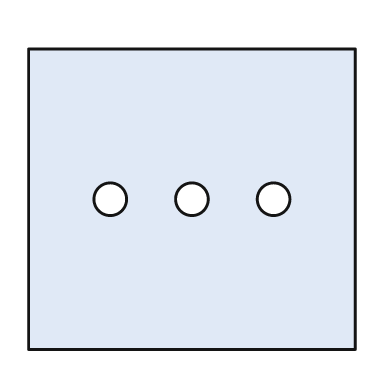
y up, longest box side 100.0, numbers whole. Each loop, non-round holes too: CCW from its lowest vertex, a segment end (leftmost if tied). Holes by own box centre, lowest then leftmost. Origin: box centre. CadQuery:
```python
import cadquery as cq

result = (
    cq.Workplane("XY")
    .moveTo(-50.0, -46.0)
    .lineTo(50.0, -46.0)
    .lineTo(50.0, 46.0)
    .lineTo(-50.0, 46.0)
    .close()
    .moveTo(-25.0, 0.0)
    .circle(5.0)
    .moveTo(0.0, 0.0)
    .circle(5.0)
    .moveTo(25.0, 0.0)
    .circle(5.0)
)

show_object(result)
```